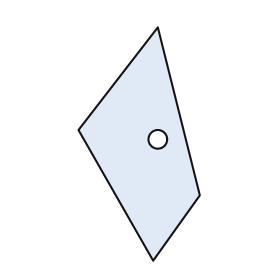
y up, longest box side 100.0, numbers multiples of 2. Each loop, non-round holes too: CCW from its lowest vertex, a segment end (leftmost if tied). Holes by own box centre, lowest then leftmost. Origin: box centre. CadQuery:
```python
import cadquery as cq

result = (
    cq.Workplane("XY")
    .moveTo(6.0, -50.0)
    .lineTo(26.0, -22.0)
    .lineTo(8.0, 50.0)
    .lineTo(-26.0, 6.0)
    .close()
    .moveTo(8.0, 2.0)
    .circle(4.0)
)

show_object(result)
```